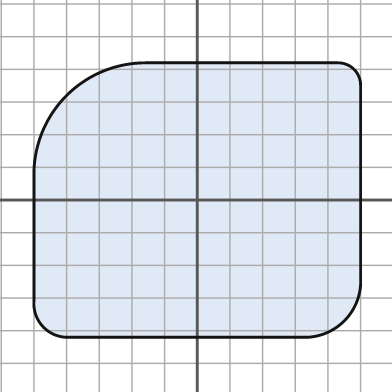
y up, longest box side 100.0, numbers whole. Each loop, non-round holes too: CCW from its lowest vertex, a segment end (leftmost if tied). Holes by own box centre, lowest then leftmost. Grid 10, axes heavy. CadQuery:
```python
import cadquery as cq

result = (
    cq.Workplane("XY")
    .moveTo(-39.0, -42.0)
    .lineTo(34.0, -42.0)
    .threePointArc((45.0, -37.0), (50.0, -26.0))
    .lineTo(50.0, 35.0)
    .threePointArc((48.0, 40.0), (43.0, 42.0))
    .lineTo(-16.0, 42.0)
    .threePointArc((-40.0, 32.0), (-50.0, 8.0))
    .lineTo(-50.0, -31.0)
    .threePointArc((-47.0, -39.0), (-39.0, -42.0))
    .close()
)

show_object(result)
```